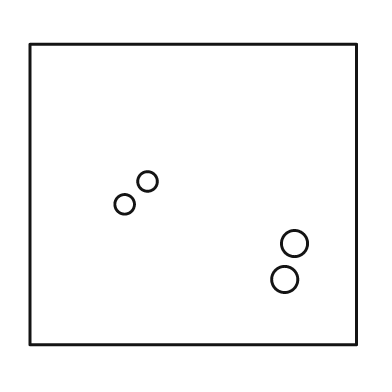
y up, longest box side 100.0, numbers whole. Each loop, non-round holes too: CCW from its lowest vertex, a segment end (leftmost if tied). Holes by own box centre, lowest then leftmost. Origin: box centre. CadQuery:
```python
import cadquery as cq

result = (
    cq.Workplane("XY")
    .moveTo(-50.0, -46.0)
    .lineTo(50.0, -46.0)
    .lineTo(50.0, 46.0)
    .lineTo(-50.0, 46.0)
    .close()
    .moveTo(28.0, -26.0)
    .circle(4.0)
    .moveTo(31.0, -15.0)
    .circle(4.0)
    .moveTo(-21.0, -3.0)
    .circle(3.0)
    .moveTo(-14.0, 4.0)
    .circle(3.0)
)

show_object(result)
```